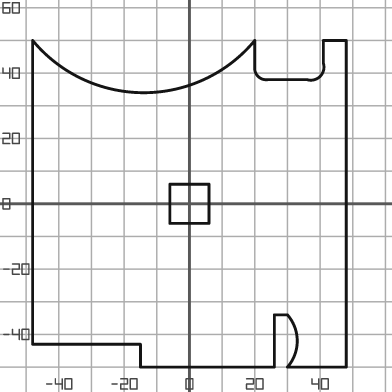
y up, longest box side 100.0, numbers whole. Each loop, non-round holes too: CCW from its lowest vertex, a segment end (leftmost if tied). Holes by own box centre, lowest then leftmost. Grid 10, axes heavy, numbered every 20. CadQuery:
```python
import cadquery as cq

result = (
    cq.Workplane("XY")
    .moveTo(-15.0, -50.0)
    .lineTo(26.0, -50.0)
    .lineTo(26.0, -34.0)
    .lineTo(30.0, -34.0)
    .threePointArc((33.0, -42.0), (30.0, -50.0))
    .lineTo(48.0, -50.0)
    .lineTo(48.0, 50.0)
    .lineTo(41.0, 50.0)
    .lineTo(41.0, 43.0)
    .threePointArc((40.0, 39.0), (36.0, 38.0))
    .lineTo(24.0, 38.0)
    .threePointArc((21.0, 39.0), (20.0, 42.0))
    .lineTo(20.0, 50.0)
    .threePointArc((-14.0, 34.0), (-48.0, 50.0))
    .lineTo(-48.0, -43.0)
    .lineTo(-15.0, -43.0)
    .close()
    .moveTo(-6.0, -6.0)
    .lineTo(6.0, -6.0)
    .lineTo(6.0, 6.0)
    .lineTo(-6.0, 6.0)
    .close()
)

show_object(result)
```